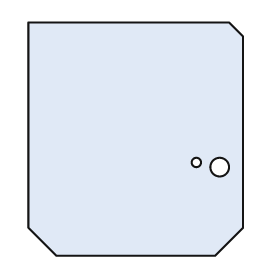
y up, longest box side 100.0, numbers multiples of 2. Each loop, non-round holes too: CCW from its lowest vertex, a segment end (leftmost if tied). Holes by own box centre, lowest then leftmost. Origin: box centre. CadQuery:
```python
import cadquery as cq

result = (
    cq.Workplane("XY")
    .moveTo(-34.0, -50.0)
    .lineTo(34.0, -50.0)
    .lineTo(46.0, -38.0)
    .lineTo(46.0, 44.0)
    .lineTo(40.0, 50.0)
    .lineTo(-46.0, 50.0)
    .lineTo(-46.0, -38.0)
    .close()
    .moveTo(36.0, -12.0)
    .circle(4.0)
    .moveTo(26.0, -10.0)
    .circle(2.0)
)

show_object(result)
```